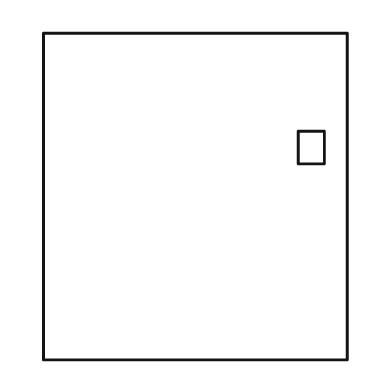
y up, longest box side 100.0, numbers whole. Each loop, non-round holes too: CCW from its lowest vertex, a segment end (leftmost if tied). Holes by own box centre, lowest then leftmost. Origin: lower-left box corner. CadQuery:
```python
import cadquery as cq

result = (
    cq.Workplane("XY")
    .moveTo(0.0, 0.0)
    .lineTo(93.0, 0.0)
    .lineTo(93.0, 100.0)
    .lineTo(0.0, 100.0)
    .close()
    .moveTo(78.0, 60.0)
    .lineTo(86.0, 60.0)
    .lineTo(86.0, 70.0)
    .lineTo(78.0, 70.0)
    .close()
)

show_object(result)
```